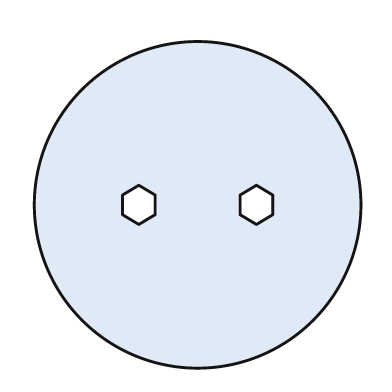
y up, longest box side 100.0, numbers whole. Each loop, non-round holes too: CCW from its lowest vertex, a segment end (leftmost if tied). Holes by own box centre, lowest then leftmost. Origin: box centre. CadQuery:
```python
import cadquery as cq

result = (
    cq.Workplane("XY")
    .moveTo(0.0, 0.0)
    .circle(50.0)
    .moveTo(-18.0, -6.0)
    .lineTo(-13.0, -3.0)
    .lineTo(-13.0, 3.0)
    .lineTo(-18.0, 6.0)
    .lineTo(-23.0, 3.0)
    .lineTo(-23.0, -3.0)
    .close()
    .moveTo(18.0, -6.0)
    .lineTo(23.0, -3.0)
    .lineTo(23.0, 3.0)
    .lineTo(18.0, 6.0)
    .lineTo(13.0, 3.0)
    .lineTo(13.0, -3.0)
    .close()
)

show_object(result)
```